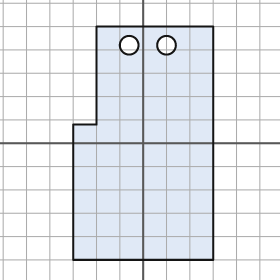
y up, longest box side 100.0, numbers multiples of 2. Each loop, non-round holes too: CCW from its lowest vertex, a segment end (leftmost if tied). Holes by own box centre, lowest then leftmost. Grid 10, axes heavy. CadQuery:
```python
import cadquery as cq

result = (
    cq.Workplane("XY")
    .moveTo(-30.0, -50.0)
    .lineTo(30.0, -50.0)
    .lineTo(30.0, 50.0)
    .lineTo(-20.0, 50.0)
    .lineTo(-20.0, 8.0)
    .lineTo(-30.0, 8.0)
    .close()
    .moveTo(-6.0, 42.0)
    .circle(4.0)
    .moveTo(10.0, 42.0)
    .circle(4.0)
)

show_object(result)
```